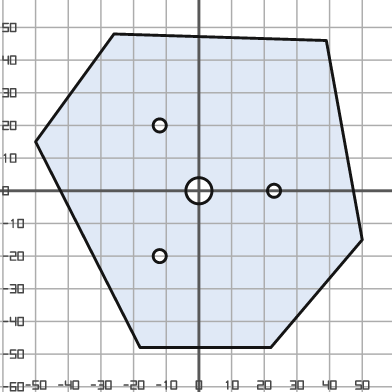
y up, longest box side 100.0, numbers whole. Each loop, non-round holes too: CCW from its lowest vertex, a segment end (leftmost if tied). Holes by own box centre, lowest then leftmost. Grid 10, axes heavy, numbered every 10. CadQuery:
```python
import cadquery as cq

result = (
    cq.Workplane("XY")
    .moveTo(-18.0, -48.0)
    .lineTo(22.0, -48.0)
    .lineTo(50.0, -15.0)
    .lineTo(39.0, 46.0)
    .lineTo(-26.0, 48.0)
    .lineTo(-50.0, 15.0)
    .close()
    .moveTo(-12.0, -20.0)
    .circle(2.0)
    .moveTo(0.0, 0.0)
    .circle(4.0)
    .moveTo(23.0, 0.0)
    .circle(2.0)
    .moveTo(-12.0, 20.0)
    .circle(2.0)
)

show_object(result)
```